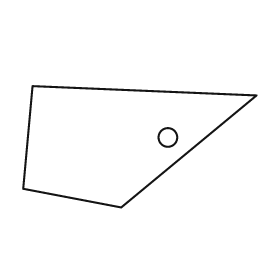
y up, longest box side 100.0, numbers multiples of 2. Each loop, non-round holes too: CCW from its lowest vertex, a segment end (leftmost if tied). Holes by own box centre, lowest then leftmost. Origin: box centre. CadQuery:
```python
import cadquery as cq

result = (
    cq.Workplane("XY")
    .moveTo(-8.0, -26.0)
    .lineTo(50.0, 22.0)
    .lineTo(-46.0, 26.0)
    .lineTo(-50.0, -18.0)
    .close()
    .moveTo(12.0, 4.0)
    .circle(4.0)
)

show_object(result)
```